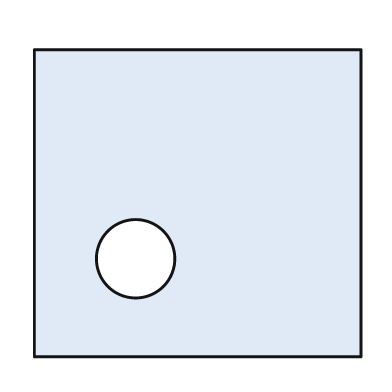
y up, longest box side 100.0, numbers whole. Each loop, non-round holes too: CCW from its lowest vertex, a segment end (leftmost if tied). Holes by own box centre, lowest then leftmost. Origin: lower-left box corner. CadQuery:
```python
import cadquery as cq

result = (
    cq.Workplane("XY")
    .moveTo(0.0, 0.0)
    .lineTo(100.0, 0.0)
    .lineTo(100.0, 94.0)
    .lineTo(0.0, 94.0)
    .close()
    .moveTo(31.0, 30.0)
    .circle(12.0)
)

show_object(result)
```